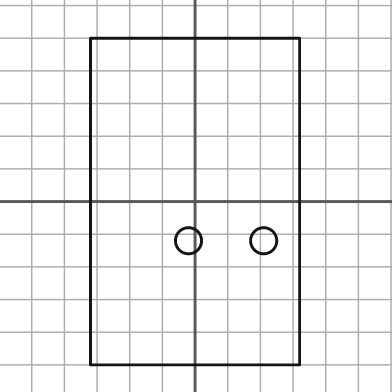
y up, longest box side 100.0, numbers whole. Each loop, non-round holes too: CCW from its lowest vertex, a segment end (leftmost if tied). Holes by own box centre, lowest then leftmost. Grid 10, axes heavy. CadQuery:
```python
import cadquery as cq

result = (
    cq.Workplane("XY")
    .moveTo(-32.0, -50.0)
    .lineTo(32.0, -50.0)
    .lineTo(32.0, 50.0)
    .lineTo(-32.0, 50.0)
    .close()
    .moveTo(-2.0, -12.0)
    .circle(4.0)
    .moveTo(21.0, -12.0)
    .circle(4.0)
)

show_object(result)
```